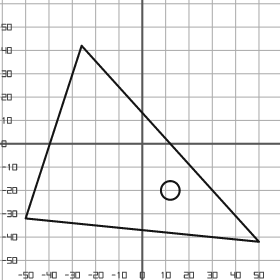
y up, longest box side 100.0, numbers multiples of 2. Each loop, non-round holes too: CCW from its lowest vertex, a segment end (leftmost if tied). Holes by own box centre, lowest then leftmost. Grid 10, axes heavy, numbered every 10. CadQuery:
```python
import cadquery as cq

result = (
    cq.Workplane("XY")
    .moveTo(50.0, -42.0)
    .lineTo(-26.0, 42.0)
    .lineTo(-50.0, -32.0)
    .close()
    .moveTo(12.0, -20.0)
    .circle(4.0)
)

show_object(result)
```